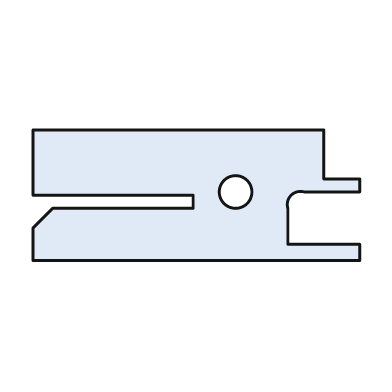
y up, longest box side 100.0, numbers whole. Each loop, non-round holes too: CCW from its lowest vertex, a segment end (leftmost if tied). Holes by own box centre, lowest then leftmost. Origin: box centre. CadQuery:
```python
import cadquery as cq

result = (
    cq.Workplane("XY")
    .moveTo(-50.0, -20.0)
    .lineTo(50.0, -20.0)
    .lineTo(50.0, -15.0)
    .lineTo(28.0, -15.0)
    .lineTo(28.0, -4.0)
    .threePointArc((29.0, 0.0), (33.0, 1.0))
    .lineTo(50.0, 1.0)
    .lineTo(50.0, 5.0)
    .lineTo(39.0, 5.0)
    .lineTo(39.0, 20.0)
    .lineTo(-50.0, 20.0)
    .lineTo(-50.0, 0.0)
    .lineTo(-1.0, 0.0)
    .lineTo(-1.0, -4.0)
    .lineTo(-44.0, -4.0)
    .lineTo(-50.0, -10.0)
    .close()
    .moveTo(12.0, 1.0)
    .circle(5.0)
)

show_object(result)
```